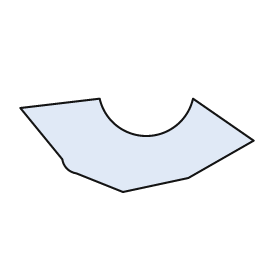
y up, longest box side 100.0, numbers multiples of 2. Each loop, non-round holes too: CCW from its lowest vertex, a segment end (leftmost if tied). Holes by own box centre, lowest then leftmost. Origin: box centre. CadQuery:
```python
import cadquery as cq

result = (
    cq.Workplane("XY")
    .moveTo(-6.0, -20.0)
    .lineTo(22.0, -14.0)
    .lineTo(50.0, 2.0)
    .lineTo(24.0, 20.0)
    .threePointArc((4.0, 4.0), (-16.0, 20.0))
    .lineTo(-50.0, 16.0)
    .lineTo(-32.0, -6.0)
    .threePointArc((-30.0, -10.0), (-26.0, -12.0))
    .close()
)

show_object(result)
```